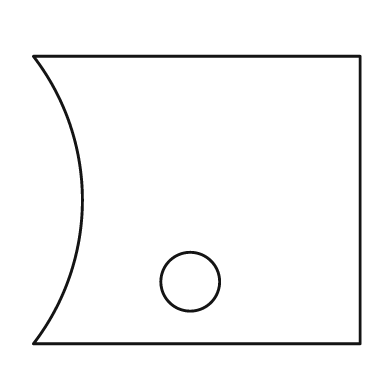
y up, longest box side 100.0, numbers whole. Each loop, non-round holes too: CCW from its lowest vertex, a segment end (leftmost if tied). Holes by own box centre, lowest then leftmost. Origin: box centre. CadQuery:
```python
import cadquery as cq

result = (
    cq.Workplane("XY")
    .moveTo(-50.0, -44.0)
    .lineTo(50.0, -44.0)
    .lineTo(50.0, 44.0)
    .lineTo(-50.0, 44.0)
    .threePointArc((-35.0, 0.0), (-50.0, -44.0))
    .close()
    .moveTo(-2.0, -25.0)
    .circle(9.0)
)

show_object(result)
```